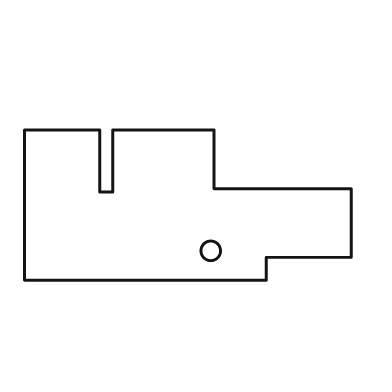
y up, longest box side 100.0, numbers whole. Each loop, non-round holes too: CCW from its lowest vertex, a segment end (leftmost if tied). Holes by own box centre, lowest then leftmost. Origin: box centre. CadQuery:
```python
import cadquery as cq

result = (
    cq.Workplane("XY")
    .moveTo(-50.0, -23.0)
    .lineTo(24.0, -23.0)
    .lineTo(24.0, -16.0)
    .lineTo(50.0, -16.0)
    .lineTo(50.0, 5.0)
    .lineTo(8.0, 5.0)
    .lineTo(8.0, 23.0)
    .lineTo(-23.0, 23.0)
    .lineTo(-23.0, 4.0)
    .lineTo(-27.0, 4.0)
    .lineTo(-27.0, 23.0)
    .lineTo(-50.0, 23.0)
    .close()
    .moveTo(7.0, -14.0)
    .circle(3.0)
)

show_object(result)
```